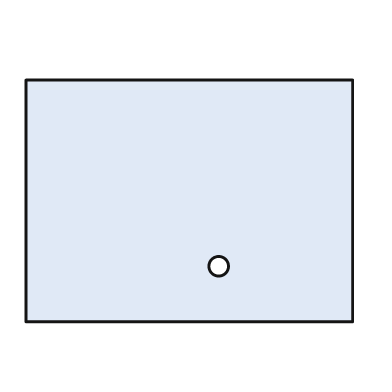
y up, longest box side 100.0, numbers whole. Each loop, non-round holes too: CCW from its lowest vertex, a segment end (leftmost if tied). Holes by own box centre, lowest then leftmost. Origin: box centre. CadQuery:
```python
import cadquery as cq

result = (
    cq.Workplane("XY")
    .moveTo(-50.0, -37.0)
    .lineTo(50.0, -37.0)
    .lineTo(50.0, 37.0)
    .lineTo(-50.0, 37.0)
    .close()
    .moveTo(9.0, -20.0)
    .circle(3.0)
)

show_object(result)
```